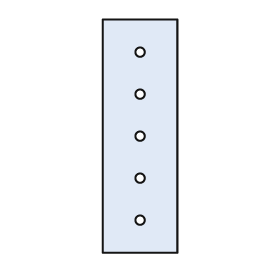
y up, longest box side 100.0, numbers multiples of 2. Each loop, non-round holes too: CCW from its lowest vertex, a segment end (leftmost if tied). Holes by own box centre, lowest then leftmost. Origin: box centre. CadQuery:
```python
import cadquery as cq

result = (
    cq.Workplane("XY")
    .moveTo(-16.0, -50.0)
    .lineTo(16.0, -50.0)
    .lineTo(16.0, 50.0)
    .lineTo(-16.0, 50.0)
    .close()
    .moveTo(0.0, -36.0)
    .circle(2.0)
    .moveTo(0.0, -18.0)
    .circle(2.0)
    .moveTo(0.0, 0.0)
    .circle(2.0)
    .moveTo(0.0, 18.0)
    .circle(2.0)
    .moveTo(0.0, 36.0)
    .circle(2.0)
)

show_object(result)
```